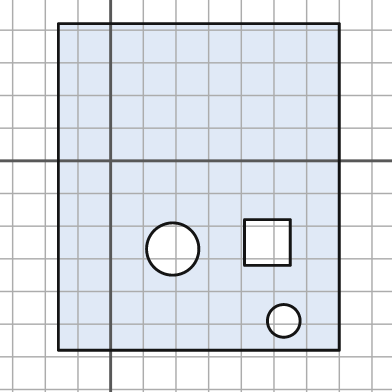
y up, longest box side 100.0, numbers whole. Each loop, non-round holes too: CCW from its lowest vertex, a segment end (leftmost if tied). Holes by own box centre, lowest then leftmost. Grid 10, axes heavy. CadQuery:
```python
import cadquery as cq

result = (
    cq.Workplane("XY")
    .moveTo(-16.0, -58.0)
    .lineTo(70.0, -58.0)
    .lineTo(70.0, 42.0)
    .lineTo(-16.0, 42.0)
    .close()
    .moveTo(53.0, -49.0)
    .circle(5.0)
    .moveTo(19.0, -27.0)
    .circle(8.0)
    .moveTo(41.0, -32.0)
    .lineTo(55.0, -32.0)
    .lineTo(55.0, -18.0)
    .lineTo(41.0, -18.0)
    .close()
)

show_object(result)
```